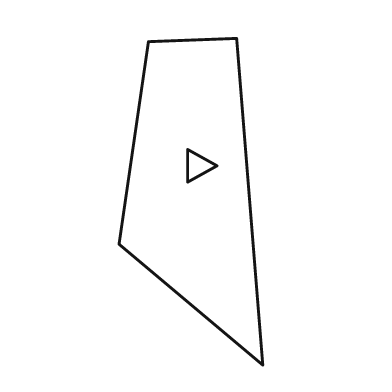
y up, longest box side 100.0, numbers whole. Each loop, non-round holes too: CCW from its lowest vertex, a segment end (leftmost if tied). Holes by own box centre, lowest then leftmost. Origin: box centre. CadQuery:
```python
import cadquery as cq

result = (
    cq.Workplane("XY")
    .moveTo(22.0, -50.0)
    .lineTo(14.0, 50.0)
    .lineTo(-13.0, 49.0)
    .lineTo(-22.0, -13.0)
    .close()
    .moveTo(-1.0, 6.0)
    .lineTo(8.0, 11.0)
    .lineTo(-1.0, 16.0)
    .close()
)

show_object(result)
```